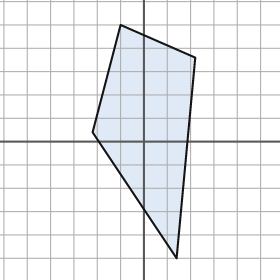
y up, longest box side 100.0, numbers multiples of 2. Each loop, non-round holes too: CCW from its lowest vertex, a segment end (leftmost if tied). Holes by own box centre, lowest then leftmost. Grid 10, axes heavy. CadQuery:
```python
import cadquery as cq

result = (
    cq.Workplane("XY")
    .moveTo(14.0, -50.0)
    .lineTo(22.0, 36.0)
    .lineTo(-10.0, 50.0)
    .lineTo(-22.0, 4.0)
    .close()
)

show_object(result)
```